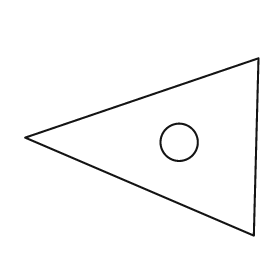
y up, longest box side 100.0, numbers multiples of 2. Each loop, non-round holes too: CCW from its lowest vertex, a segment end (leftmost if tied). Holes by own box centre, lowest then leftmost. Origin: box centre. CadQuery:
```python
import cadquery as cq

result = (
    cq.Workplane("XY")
    .moveTo(48.0, -38.0)
    .lineTo(50.0, 38.0)
    .lineTo(-50.0, 4.0)
    .close()
    .moveTo(16.0, 2.0)
    .circle(8.0)
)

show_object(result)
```